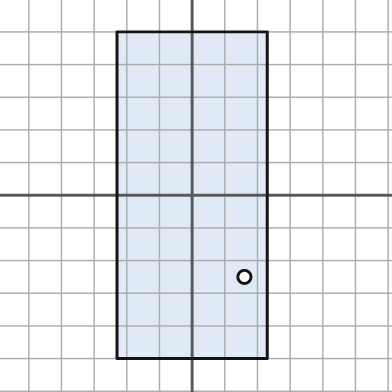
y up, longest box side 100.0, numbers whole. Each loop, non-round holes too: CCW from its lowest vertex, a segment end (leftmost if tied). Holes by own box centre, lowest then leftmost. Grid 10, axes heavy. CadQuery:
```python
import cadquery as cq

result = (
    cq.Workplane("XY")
    .moveTo(-23.0, -50.0)
    .lineTo(23.0, -50.0)
    .lineTo(23.0, 50.0)
    .lineTo(-23.0, 50.0)
    .close()
    .moveTo(16.0, -25.0)
    .circle(2.0)
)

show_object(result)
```